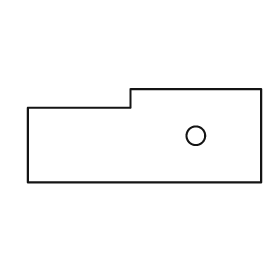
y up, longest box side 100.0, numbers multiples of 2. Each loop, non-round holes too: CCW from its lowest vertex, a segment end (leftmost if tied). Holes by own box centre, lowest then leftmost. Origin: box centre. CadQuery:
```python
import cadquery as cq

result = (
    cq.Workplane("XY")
    .moveTo(-50.0, -20.0)
    .lineTo(50.0, -20.0)
    .lineTo(50.0, 20.0)
    .lineTo(-6.0, 20.0)
    .lineTo(-6.0, 12.0)
    .lineTo(-50.0, 12.0)
    .close()
    .moveTo(22.0, 0.0)
    .circle(4.0)
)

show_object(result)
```